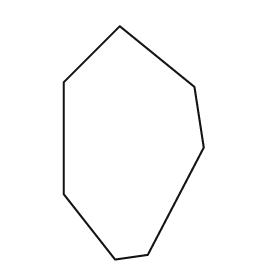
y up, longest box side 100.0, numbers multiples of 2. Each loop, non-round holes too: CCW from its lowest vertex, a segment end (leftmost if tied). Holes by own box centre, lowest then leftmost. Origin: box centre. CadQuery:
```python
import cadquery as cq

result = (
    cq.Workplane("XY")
    .moveTo(-8.0, -50.0)
    .lineTo(6.0, -48.0)
    .lineTo(30.0, -2.0)
    .lineTo(26.0, 24.0)
    .lineTo(-6.0, 50.0)
    .lineTo(-30.0, 26.0)
    .lineTo(-30.0, -22.0)
    .close()
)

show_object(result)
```